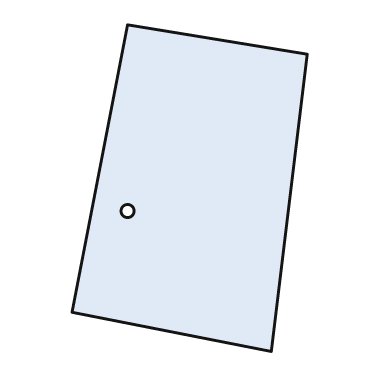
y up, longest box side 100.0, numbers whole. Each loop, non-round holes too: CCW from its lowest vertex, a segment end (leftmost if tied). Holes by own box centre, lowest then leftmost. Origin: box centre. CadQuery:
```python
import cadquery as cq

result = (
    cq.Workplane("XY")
    .moveTo(25.0, -50.0)
    .lineTo(36.0, 41.0)
    .lineTo(-19.0, 50.0)
    .lineTo(-36.0, -38.0)
    .close()
    .moveTo(-19.0, -7.0)
    .circle(2.0)
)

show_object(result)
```